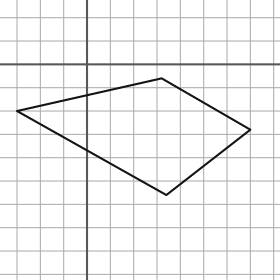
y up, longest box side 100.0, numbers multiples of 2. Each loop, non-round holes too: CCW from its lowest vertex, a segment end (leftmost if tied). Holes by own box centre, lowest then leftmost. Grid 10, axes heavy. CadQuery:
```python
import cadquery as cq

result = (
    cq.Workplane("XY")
    .moveTo(34.0, -56.0)
    .lineTo(70.0, -28.0)
    .lineTo(32.0, -6.0)
    .lineTo(-30.0, -20.0)
    .close()
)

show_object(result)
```